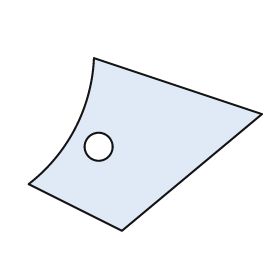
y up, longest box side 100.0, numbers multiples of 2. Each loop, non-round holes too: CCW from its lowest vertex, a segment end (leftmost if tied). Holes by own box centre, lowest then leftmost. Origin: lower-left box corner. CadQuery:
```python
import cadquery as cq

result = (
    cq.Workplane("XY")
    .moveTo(40.0, 0.0)
    .lineTo(100.0, 50.0)
    .lineTo(28.0, 74.0)
    .threePointArc((20.0, 44.0), (0.0, 20.0))
    .close()
    .moveTo(30.0, 36.0)
    .circle(6.0)
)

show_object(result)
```